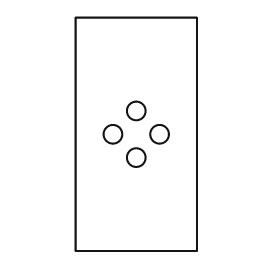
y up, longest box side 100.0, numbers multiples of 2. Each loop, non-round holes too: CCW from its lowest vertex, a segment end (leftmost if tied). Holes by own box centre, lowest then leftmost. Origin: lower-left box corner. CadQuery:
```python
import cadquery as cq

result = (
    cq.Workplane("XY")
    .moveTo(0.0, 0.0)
    .lineTo(52.0, 0.0)
    .lineTo(52.0, 100.0)
    .lineTo(0.0, 100.0)
    .close()
    .moveTo(26.0, 40.0)
    .circle(4.0)
    .moveTo(16.0, 50.0)
    .circle(4.0)
    .moveTo(36.0, 50.0)
    .circle(4.0)
    .moveTo(26.0, 60.0)
    .circle(4.0)
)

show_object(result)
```